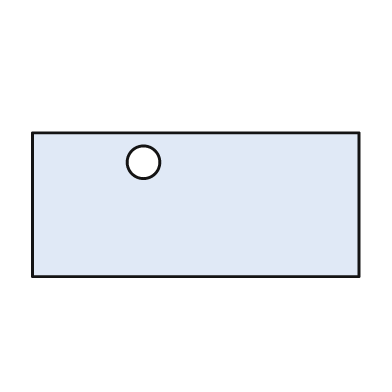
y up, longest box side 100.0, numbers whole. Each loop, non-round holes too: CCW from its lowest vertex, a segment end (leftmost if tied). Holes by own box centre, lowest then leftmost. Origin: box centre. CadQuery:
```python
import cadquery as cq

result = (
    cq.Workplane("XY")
    .moveTo(-50.0, -22.0)
    .lineTo(50.0, -22.0)
    .lineTo(50.0, 22.0)
    .lineTo(-50.0, 22.0)
    .close()
    .moveTo(-16.0, 13.0)
    .circle(5.0)
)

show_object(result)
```